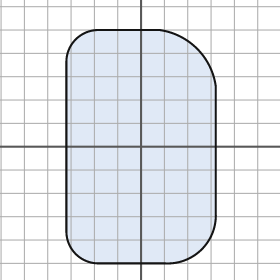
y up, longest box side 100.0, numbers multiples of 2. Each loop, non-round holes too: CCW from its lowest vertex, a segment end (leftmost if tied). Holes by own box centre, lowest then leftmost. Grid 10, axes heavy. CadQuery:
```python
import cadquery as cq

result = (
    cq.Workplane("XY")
    .moveTo(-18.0, -50.0)
    .lineTo(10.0, -50.0)
    .threePointArc((26.0, -44.0), (32.0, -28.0))
    .lineTo(32.0, 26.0)
    .threePointArc((24.0, 42.0), (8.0, 50.0))
    .lineTo(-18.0, 50.0)
    .threePointArc((-28.0, 46.0), (-32.0, 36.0))
    .lineTo(-32.0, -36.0)
    .threePointArc((-28.0, -46.0), (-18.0, -50.0))
    .close()
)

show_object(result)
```